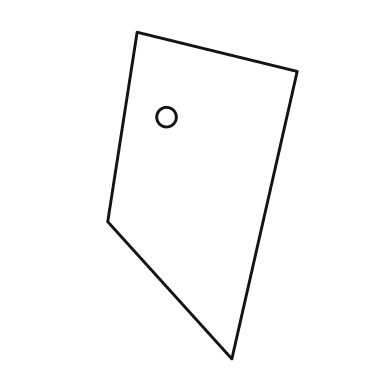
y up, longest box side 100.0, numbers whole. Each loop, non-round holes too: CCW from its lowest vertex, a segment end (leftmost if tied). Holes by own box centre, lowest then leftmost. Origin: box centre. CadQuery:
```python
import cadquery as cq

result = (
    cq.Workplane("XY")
    .moveTo(9.0, -50.0)
    .lineTo(29.0, 38.0)
    .lineTo(-20.0, 50.0)
    .lineTo(-29.0, -8.0)
    .close()
    .moveTo(-11.0, 24.0)
    .circle(3.0)
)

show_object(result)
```